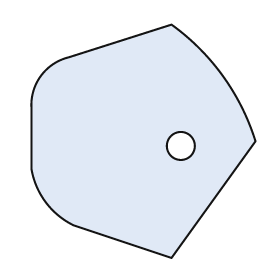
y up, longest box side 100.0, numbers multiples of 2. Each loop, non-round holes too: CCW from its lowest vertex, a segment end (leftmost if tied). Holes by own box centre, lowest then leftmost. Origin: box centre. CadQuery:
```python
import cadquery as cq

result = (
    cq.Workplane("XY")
    .moveTo(12.0, -50.0)
    .lineTo(48.0, 0.0)
    .threePointArc((34.0, 28.0), (12.0, 50.0))
    .lineTo(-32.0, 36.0)
    .threePointArc((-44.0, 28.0), (-48.0, 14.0))
    .lineTo(-48.0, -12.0)
    .threePointArc((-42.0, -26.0), (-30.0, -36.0))
    .close()
    .moveTo(16.0, -2.0)
    .circle(6.0)
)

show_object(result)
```